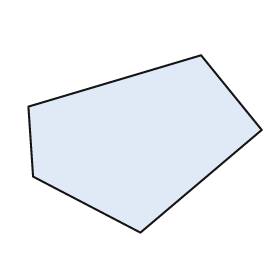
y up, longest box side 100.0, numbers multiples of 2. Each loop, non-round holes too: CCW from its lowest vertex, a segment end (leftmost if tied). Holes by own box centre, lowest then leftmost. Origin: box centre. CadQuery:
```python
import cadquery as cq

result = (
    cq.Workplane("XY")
    .moveTo(-2.0, -38.0)
    .lineTo(50.0, 6.0)
    .lineTo(24.0, 38.0)
    .lineTo(-50.0, 16.0)
    .lineTo(-48.0, -14.0)
    .close()
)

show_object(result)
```